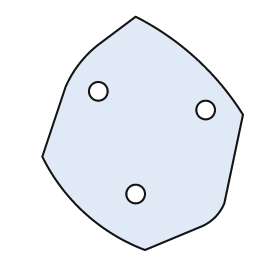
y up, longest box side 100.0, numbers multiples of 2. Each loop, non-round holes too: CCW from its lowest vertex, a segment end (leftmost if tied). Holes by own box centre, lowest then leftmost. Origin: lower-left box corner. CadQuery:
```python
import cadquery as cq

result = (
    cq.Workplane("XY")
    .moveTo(44.0, 0.0)
    .lineTo(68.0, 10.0)
    .threePointArc((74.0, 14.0), (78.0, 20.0))
    .lineTo(86.0, 58.0)
    .threePointArc((66.0, 82.0), (40.0, 100.0))
    .lineTo(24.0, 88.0)
    .threePointArc((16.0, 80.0), (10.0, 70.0))
    .lineTo(0.0, 40.0)
    .threePointArc((18.0, 16.0), (44.0, 0.0))
    .close()
    .moveTo(40.0, 24.0)
    .circle(4.0)
    .moveTo(70.0, 60.0)
    .circle(4.0)
    .moveTo(24.0, 68.0)
    .circle(4.0)
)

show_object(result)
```